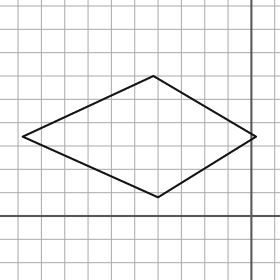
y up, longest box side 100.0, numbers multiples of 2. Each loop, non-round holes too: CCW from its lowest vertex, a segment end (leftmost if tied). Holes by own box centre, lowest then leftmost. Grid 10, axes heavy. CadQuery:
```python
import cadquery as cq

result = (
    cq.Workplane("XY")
    .moveTo(-40.0, 8.0)
    .lineTo(2.0, 34.0)
    .lineTo(-42.0, 60.0)
    .lineTo(-98.0, 34.0)
    .close()
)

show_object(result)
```